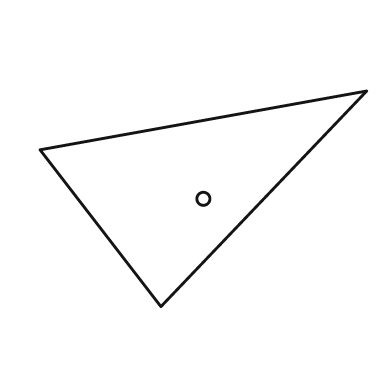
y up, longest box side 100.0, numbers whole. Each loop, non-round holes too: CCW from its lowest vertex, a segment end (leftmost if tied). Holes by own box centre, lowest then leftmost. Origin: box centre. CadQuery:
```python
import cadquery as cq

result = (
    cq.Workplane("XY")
    .moveTo(-13.0, -33.0)
    .lineTo(50.0, 33.0)
    .lineTo(-50.0, 15.0)
    .close()
    .moveTo(0.0, 0.0)
    .circle(2.0)
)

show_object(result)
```